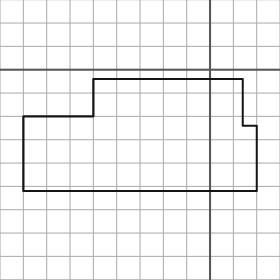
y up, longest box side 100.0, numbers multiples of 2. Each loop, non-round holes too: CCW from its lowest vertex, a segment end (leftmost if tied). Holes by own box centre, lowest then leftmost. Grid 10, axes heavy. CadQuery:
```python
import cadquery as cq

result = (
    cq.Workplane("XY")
    .moveTo(-80.0, -52.0)
    .lineTo(20.0, -52.0)
    .lineTo(20.0, -24.0)
    .lineTo(14.0, -24.0)
    .lineTo(14.0, -4.0)
    .lineTo(-50.0, -4.0)
    .lineTo(-50.0, -20.0)
    .lineTo(-80.0, -20.0)
    .close()
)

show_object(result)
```